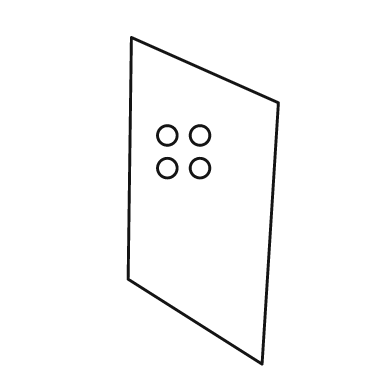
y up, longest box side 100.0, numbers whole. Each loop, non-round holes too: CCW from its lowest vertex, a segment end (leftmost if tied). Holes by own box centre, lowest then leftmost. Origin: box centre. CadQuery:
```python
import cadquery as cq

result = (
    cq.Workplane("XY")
    .moveTo(18.0, -50.0)
    .lineTo(23.0, 30.0)
    .lineTo(-22.0, 50.0)
    .lineTo(-23.0, -24.0)
    .close()
    .moveTo(-11.0, 10.0)
    .circle(3.0)
    .moveTo(-1.0, 10.0)
    .circle(3.0)
    .moveTo(-11.0, 20.0)
    .circle(3.0)
    .moveTo(-1.0, 20.0)
    .circle(3.0)
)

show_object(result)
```